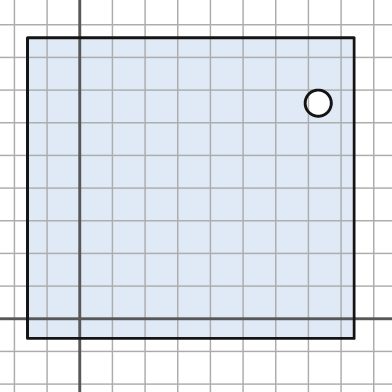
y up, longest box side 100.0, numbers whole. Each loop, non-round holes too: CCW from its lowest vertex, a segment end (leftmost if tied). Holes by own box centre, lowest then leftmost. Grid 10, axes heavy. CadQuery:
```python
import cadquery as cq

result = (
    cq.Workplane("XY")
    .moveTo(-16.0, -6.0)
    .lineTo(84.0, -6.0)
    .lineTo(84.0, 86.0)
    .lineTo(-16.0, 86.0)
    .close()
    .moveTo(73.0, 66.0)
    .circle(4.0)
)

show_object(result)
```